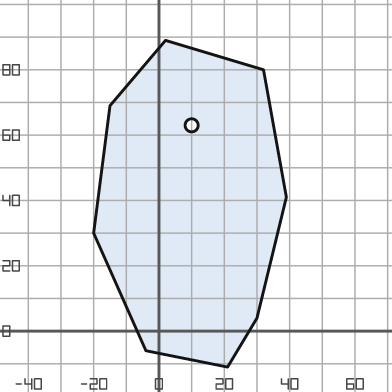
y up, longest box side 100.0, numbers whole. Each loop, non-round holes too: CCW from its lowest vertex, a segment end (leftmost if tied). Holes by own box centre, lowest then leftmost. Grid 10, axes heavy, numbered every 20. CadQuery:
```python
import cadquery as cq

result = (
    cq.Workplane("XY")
    .moveTo(21.0, -11.0)
    .lineTo(30.0, 4.0)
    .lineTo(39.0, 41.0)
    .lineTo(32.0, 80.0)
    .lineTo(2.0, 89.0)
    .lineTo(-15.0, 69.0)
    .lineTo(-20.0, 30.0)
    .lineTo(-4.0, -6.0)
    .close()
    .moveTo(10.0, 63.0)
    .circle(2.0)
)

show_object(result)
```